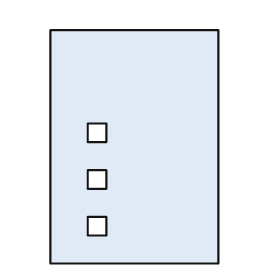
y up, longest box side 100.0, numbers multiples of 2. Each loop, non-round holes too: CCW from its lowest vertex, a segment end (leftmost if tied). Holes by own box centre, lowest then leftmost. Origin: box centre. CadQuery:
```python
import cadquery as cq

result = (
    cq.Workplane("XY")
    .moveTo(-36.0, -50.0)
    .lineTo(36.0, -50.0)
    .lineTo(36.0, 50.0)
    .lineTo(-36.0, 50.0)
    .close()
    .moveTo(-20.0, -38.0)
    .lineTo(-12.0, -38.0)
    .lineTo(-12.0, -30.0)
    .lineTo(-20.0, -30.0)
    .close()
    .moveTo(-20.0, -18.0)
    .lineTo(-12.0, -18.0)
    .lineTo(-12.0, -10.0)
    .lineTo(-20.0, -10.0)
    .close()
    .moveTo(-20.0, 2.0)
    .lineTo(-12.0, 2.0)
    .lineTo(-12.0, 10.0)
    .lineTo(-20.0, 10.0)
    .close()
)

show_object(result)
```